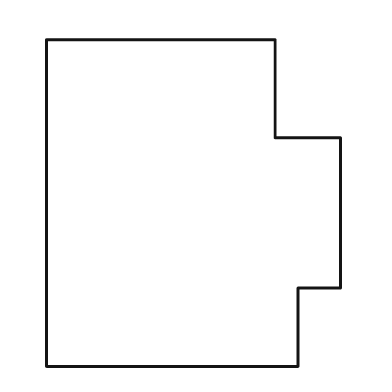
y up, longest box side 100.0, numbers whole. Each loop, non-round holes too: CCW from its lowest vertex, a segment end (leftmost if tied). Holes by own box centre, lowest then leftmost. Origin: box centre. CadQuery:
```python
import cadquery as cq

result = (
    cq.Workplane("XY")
    .moveTo(-45.0, -50.0)
    .lineTo(32.0, -50.0)
    .lineTo(32.0, -26.0)
    .lineTo(45.0, -26.0)
    .lineTo(45.0, 20.0)
    .lineTo(25.0, 20.0)
    .lineTo(25.0, 50.0)
    .lineTo(-45.0, 50.0)
    .close()
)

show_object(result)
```